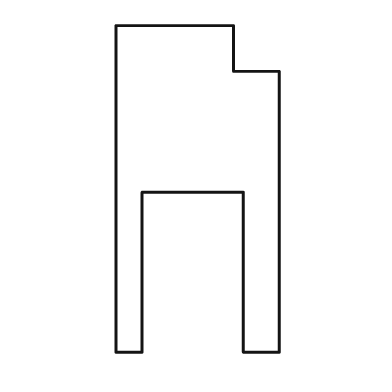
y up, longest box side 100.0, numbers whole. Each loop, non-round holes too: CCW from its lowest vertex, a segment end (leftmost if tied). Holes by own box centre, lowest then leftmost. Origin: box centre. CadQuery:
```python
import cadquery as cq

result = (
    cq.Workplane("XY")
    .moveTo(-25.0, -50.0)
    .lineTo(-17.0, -50.0)
    .lineTo(-17.0, -1.0)
    .lineTo(14.0, -1.0)
    .lineTo(14.0, -50.0)
    .lineTo(25.0, -50.0)
    .lineTo(25.0, 36.0)
    .lineTo(11.0, 36.0)
    .lineTo(11.0, 50.0)
    .lineTo(-25.0, 50.0)
    .close()
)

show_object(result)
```